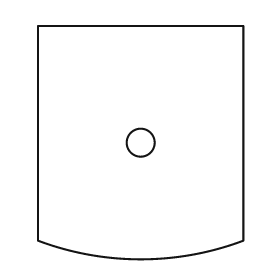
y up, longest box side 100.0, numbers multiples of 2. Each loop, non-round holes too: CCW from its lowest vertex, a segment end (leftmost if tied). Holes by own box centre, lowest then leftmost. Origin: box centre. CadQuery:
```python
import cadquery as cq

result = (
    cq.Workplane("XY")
    .moveTo(-44.0, -42.0)
    .threePointArc((0.0, -50.0), (44.0, -42.0))
    .lineTo(44.0, 50.0)
    .lineTo(-44.0, 50.0)
    .close()
    .moveTo(0.0, 0.0)
    .circle(6.0)
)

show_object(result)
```